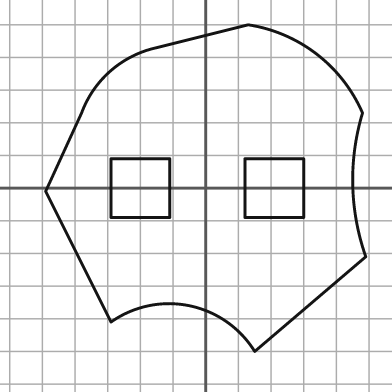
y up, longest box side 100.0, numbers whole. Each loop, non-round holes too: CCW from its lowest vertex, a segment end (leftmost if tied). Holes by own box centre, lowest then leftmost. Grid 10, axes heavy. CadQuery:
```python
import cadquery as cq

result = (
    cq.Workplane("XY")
    .moveTo(15.0, -50.0)
    .lineTo(49.0, -21.0)
    .threePointArc((45.0, 1.0), (48.0, 23.0))
    .threePointArc((34.0, 41.0), (13.0, 50.0))
    .lineTo(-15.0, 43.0)
    .threePointArc((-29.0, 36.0), (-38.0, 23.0))
    .lineTo(-49.0, -1.0)
    .lineTo(-29.0, -41.0)
    .threePointArc((-5.0, -36.0), (15.0, -50.0))
    .close()
    .moveTo(-29.0, -9.0)
    .lineTo(-11.0, -9.0)
    .lineTo(-11.0, 9.0)
    .lineTo(-29.0, 9.0)
    .close()
    .moveTo(12.0, -9.0)
    .lineTo(30.0, -9.0)
    .lineTo(30.0, 9.0)
    .lineTo(12.0, 9.0)
    .close()
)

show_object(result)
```